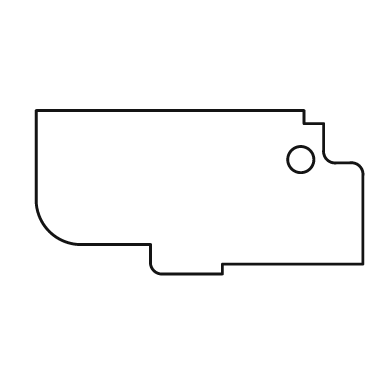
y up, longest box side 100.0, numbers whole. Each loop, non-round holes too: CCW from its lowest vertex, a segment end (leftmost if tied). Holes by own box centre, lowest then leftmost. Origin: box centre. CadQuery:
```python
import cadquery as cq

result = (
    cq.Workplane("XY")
    .moveTo(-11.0, -25.0)
    .lineTo(7.0, -25.0)
    .lineTo(7.0, -22.0)
    .lineTo(50.0, -22.0)
    .lineTo(50.0, 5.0)
    .threePointArc((49.0, 8.0), (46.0, 9.0))
    .lineTo(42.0, 9.0)
    .threePointArc((39.0, 10.0), (38.0, 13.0))
    .lineTo(38.0, 21.0)
    .lineTo(32.0, 21.0)
    .lineTo(32.0, 25.0)
    .lineTo(-50.0, 25.0)
    .lineTo(-50.0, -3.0)
    .threePointArc((-46.0, -12.0), (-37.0, -16.0))
    .lineTo(-15.0, -16.0)
    .lineTo(-15.0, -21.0)
    .threePointArc((-14.0, -24.0), (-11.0, -25.0))
    .close()
    .moveTo(31.0, 10.0)
    .circle(4.0)
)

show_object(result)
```